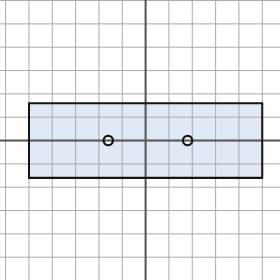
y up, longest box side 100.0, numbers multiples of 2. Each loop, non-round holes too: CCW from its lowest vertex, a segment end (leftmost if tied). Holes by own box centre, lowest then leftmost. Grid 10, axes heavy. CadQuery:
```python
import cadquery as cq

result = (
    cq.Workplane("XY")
    .moveTo(-50.0, -16.0)
    .lineTo(50.0, -16.0)
    .lineTo(50.0, 16.0)
    .lineTo(-50.0, 16.0)
    .close()
    .moveTo(-16.0, 0.0)
    .circle(2.0)
    .moveTo(18.0, 0.0)
    .circle(2.0)
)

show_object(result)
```